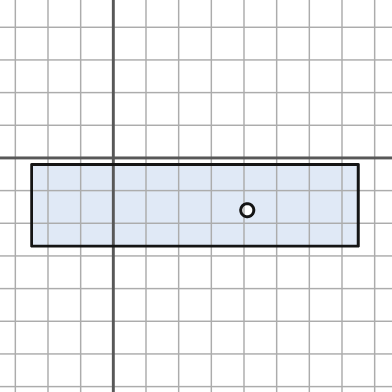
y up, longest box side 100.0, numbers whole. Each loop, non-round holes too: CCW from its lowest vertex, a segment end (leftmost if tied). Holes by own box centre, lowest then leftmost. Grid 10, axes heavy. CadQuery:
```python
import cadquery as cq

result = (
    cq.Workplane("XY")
    .moveTo(-25.0, -27.0)
    .lineTo(75.0, -27.0)
    .lineTo(75.0, -2.0)
    .lineTo(-25.0, -2.0)
    .close()
    .moveTo(41.0, -16.0)
    .circle(2.0)
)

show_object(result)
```